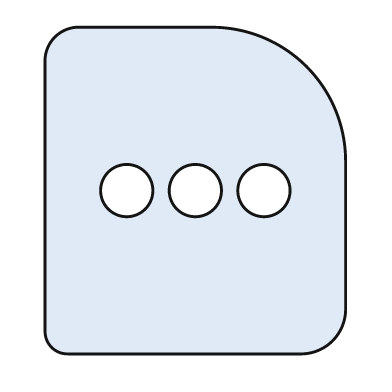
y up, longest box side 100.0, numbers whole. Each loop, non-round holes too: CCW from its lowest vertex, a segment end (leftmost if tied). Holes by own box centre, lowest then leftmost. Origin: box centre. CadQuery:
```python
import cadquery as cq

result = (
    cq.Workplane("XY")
    .moveTo(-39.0, -50.0)
    .lineTo(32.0, -50.0)
    .threePointArc((42.0, -46.0), (46.0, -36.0))
    .lineTo(46.0, 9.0)
    .threePointArc((34.0, 38.0), (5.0, 50.0))
    .lineTo(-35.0, 50.0)
    .threePointArc((-43.0, 47.0), (-46.0, 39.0))
    .lineTo(-46.0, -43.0)
    .threePointArc((-44.0, -48.0), (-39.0, -50.0))
    .close()
    .moveTo(-21.0, 0.0)
    .circle(8.0)
    .moveTo(0.0, 0.0)
    .circle(8.0)
    .moveTo(21.0, 0.0)
    .circle(8.0)
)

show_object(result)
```